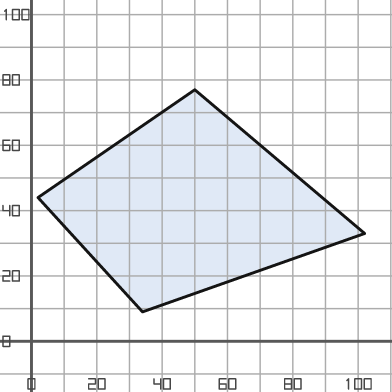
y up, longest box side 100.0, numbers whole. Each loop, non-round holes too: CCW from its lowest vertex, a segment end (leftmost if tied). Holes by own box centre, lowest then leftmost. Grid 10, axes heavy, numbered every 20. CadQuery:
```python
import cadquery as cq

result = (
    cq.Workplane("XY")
    .moveTo(34.0, 9.0)
    .lineTo(102.0, 33.0)
    .lineTo(50.0, 77.0)
    .lineTo(2.0, 44.0)
    .close()
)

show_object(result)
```